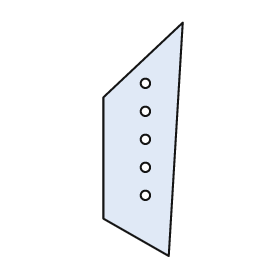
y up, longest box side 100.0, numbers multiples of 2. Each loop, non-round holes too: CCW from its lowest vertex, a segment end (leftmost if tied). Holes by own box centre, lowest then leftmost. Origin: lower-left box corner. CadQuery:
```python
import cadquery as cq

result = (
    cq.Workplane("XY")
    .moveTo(28.0, 0.0)
    .lineTo(34.0, 100.0)
    .lineTo(0.0, 68.0)
    .lineTo(0.0, 16.0)
    .close()
    .moveTo(18.0, 26.0)
    .circle(2.0)
    .moveTo(18.0, 38.0)
    .circle(2.0)
    .moveTo(18.0, 50.0)
    .circle(2.0)
    .moveTo(18.0, 62.0)
    .circle(2.0)
    .moveTo(18.0, 74.0)
    .circle(2.0)
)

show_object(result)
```